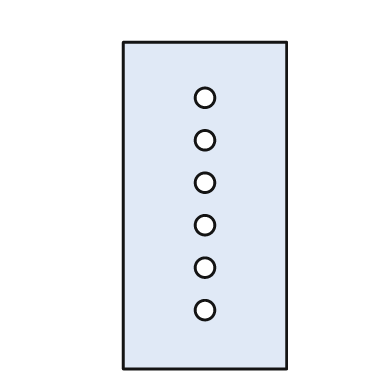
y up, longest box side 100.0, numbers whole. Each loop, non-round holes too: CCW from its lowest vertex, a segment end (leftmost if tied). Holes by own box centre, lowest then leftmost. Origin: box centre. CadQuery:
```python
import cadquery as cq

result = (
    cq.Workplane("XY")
    .moveTo(-25.0, -50.0)
    .lineTo(25.0, -50.0)
    .lineTo(25.0, 50.0)
    .lineTo(-25.0, 50.0)
    .close()
    .moveTo(0.0, -32.0)
    .circle(3.0)
    .moveTo(0.0, -19.0)
    .circle(3.0)
    .moveTo(0.0, -6.0)
    .circle(3.0)
    .moveTo(0.0, 7.0)
    .circle(3.0)
    .moveTo(0.0, 20.0)
    .circle(3.0)
    .moveTo(0.0, 33.0)
    .circle(3.0)
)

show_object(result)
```